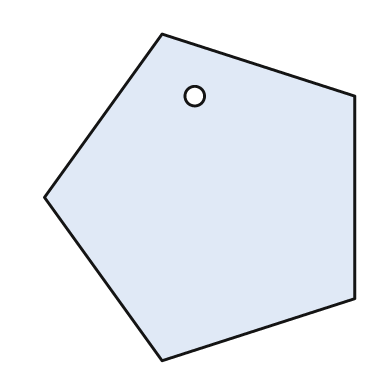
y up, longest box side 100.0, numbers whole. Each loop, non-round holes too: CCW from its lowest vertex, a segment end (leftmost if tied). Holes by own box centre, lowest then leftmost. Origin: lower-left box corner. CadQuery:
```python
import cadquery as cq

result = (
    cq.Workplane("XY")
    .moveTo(36.0, 0.0)
    .lineTo(95.0, 19.0)
    .lineTo(95.0, 81.0)
    .lineTo(36.0, 100.0)
    .lineTo(0.0, 50.0)
    .close()
    .moveTo(46.0, 81.0)
    .circle(3.0)
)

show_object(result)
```